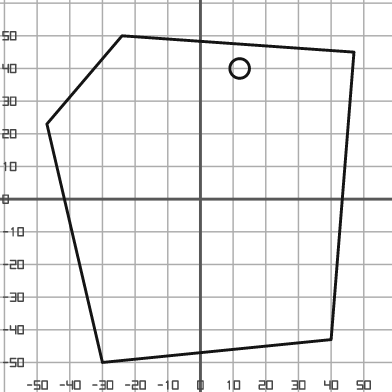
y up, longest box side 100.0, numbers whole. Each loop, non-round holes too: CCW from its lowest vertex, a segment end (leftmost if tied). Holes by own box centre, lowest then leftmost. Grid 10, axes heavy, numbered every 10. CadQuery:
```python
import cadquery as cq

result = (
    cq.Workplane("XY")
    .moveTo(-30.0, -50.0)
    .lineTo(40.0, -43.0)
    .lineTo(47.0, 45.0)
    .lineTo(-24.0, 50.0)
    .lineTo(-47.0, 23.0)
    .close()
    .moveTo(12.0, 40.0)
    .circle(3.0)
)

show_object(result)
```